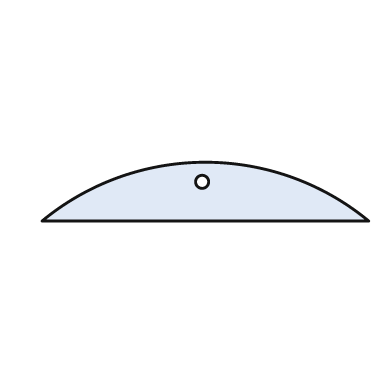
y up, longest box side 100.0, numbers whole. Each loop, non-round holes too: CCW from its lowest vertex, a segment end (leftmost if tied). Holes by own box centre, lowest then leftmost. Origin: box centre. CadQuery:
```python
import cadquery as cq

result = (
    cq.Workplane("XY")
    .moveTo(-50.0, -9.0)
    .lineTo(50.0, -9.0)
    .threePointArc((0.0, 9.0), (-50.0, -9.0))
    .close()
    .moveTo(-1.0, 3.0)
    .circle(2.0)
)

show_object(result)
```